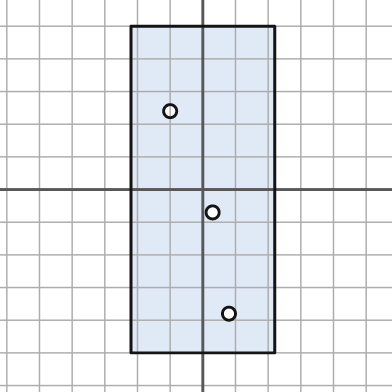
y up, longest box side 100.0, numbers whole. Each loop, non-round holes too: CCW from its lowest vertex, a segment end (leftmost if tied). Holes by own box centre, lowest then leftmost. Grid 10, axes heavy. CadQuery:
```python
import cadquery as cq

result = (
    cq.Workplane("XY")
    .moveTo(-22.0, -50.0)
    .lineTo(22.0, -50.0)
    .lineTo(22.0, 50.0)
    .lineTo(-22.0, 50.0)
    .close()
    .moveTo(8.0, -38.0)
    .circle(2.0)
    .moveTo(3.0, -7.0)
    .circle(2.0)
    .moveTo(-10.0, 24.0)
    .circle(2.0)
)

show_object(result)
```